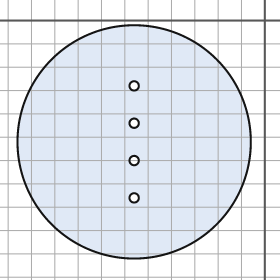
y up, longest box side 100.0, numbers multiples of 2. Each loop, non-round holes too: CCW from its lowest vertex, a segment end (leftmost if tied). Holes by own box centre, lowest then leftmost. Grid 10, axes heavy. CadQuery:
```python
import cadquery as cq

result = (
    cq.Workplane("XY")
    .moveTo(-56.0, -52.0)
    .circle(50.0)
    .moveTo(-56.0, -76.0)
    .circle(2.0)
    .moveTo(-56.0, -60.0)
    .circle(2.0)
    .moveTo(-56.0, -44.0)
    .circle(2.0)
    .moveTo(-56.0, -28.0)
    .circle(2.0)
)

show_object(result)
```